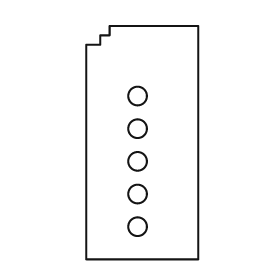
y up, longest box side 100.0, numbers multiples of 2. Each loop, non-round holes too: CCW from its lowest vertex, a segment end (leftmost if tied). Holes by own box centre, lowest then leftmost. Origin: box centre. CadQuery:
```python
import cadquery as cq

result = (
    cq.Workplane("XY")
    .moveTo(-24.0, -50.0)
    .lineTo(24.0, -50.0)
    .lineTo(24.0, 50.0)
    .lineTo(-14.0, 50.0)
    .lineTo(-14.0, 46.0)
    .lineTo(-18.0, 46.0)
    .lineTo(-18.0, 42.0)
    .lineTo(-24.0, 42.0)
    .close()
    .moveTo(-2.0, -36.0)
    .circle(4.0)
    .moveTo(-2.0, -22.0)
    .circle(4.0)
    .moveTo(-2.0, -8.0)
    .circle(4.0)
    .moveTo(-2.0, 6.0)
    .circle(4.0)
    .moveTo(-2.0, 20.0)
    .circle(4.0)
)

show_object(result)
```